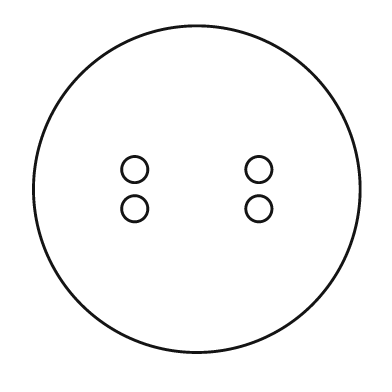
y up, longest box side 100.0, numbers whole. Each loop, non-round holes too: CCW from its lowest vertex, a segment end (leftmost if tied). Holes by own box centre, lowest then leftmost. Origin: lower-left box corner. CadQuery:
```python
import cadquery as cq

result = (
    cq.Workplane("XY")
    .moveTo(50.0, 50.0)
    .circle(50.0)
    .moveTo(31.0, 44.0)
    .circle(4.0)
    .moveTo(69.0, 44.0)
    .circle(4.0)
    .moveTo(31.0, 56.0)
    .circle(4.0)
    .moveTo(69.0, 56.0)
    .circle(4.0)
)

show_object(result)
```